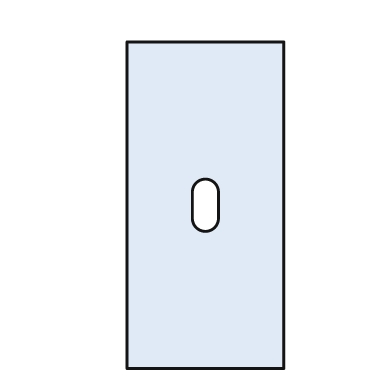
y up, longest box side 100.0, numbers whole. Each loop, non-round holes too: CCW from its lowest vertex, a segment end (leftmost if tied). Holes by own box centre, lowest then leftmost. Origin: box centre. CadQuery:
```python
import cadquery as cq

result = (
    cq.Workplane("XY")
    .moveTo(-24.0, -50.0)
    .lineTo(24.0, -50.0)
    .lineTo(24.0, 50.0)
    .lineTo(-24.0, 50.0)
    .close()
    .moveTo(-4.0, -4.0)
    .threePointArc((0.0, -8.0), (4.0, -4.0))
    .lineTo(4.0, 4.0)
    .threePointArc((0.0, 8.0), (-4.0, 4.0))
    .close()
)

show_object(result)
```